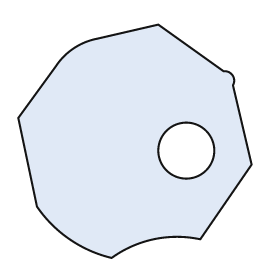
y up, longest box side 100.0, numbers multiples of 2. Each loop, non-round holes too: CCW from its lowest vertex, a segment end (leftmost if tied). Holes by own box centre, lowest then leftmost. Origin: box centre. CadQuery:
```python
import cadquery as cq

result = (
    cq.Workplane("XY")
    .moveTo(-10.0, -50.0)
    .threePointArc((8.0, -42.0), (28.0, -42.0))
    .lineTo(50.0, -10.0)
    .lineTo(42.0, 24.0)
    .threePointArc((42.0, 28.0), (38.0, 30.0))
    .lineTo(10.0, 50.0)
    .lineTo(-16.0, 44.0)
    .threePointArc((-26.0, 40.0), (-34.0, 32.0))
    .lineTo(-50.0, 10.0)
    .lineTo(-42.0, -28.0)
    .threePointArc((-28.0, -42.0), (-10.0, -50.0))
    .close()
    .moveTo(22.0, -4.0)
    .circle(12.0)
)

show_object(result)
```